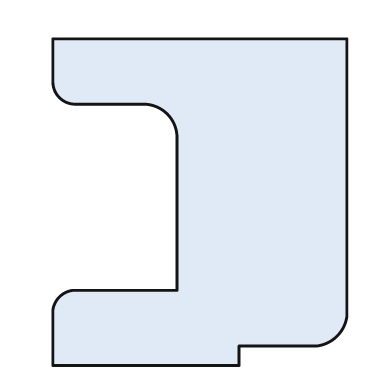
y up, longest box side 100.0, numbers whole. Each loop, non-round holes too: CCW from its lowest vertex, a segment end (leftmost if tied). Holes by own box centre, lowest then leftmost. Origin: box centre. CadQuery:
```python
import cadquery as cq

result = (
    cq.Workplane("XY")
    .moveTo(-45.0, -50.0)
    .lineTo(12.0, -50.0)
    .lineTo(12.0, -44.0)
    .lineTo(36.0, -44.0)
    .threePointArc((42.0, -41.0), (45.0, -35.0))
    .lineTo(45.0, 50.0)
    .lineTo(-45.0, 50.0)
    .lineTo(-45.0, 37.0)
    .threePointArc((-43.0, 32.0), (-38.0, 30.0))
    .lineTo(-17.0, 30.0)
    .threePointArc((-10.0, 27.0), (-7.0, 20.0))
    .lineTo(-7.0, -27.0)
    .lineTo(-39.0, -27.0)
    .threePointArc((-43.0, -29.0), (-45.0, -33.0))
    .close()
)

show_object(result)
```